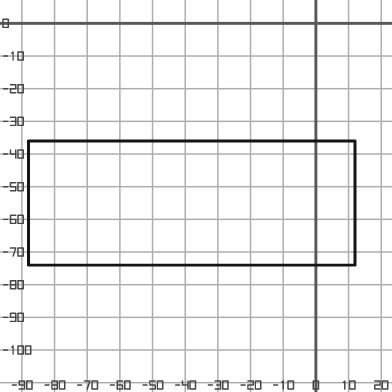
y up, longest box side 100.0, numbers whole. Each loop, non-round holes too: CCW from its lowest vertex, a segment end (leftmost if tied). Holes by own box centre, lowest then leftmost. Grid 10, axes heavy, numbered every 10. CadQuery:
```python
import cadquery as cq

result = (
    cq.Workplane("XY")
    .moveTo(-88.0, -74.0)
    .lineTo(12.0, -74.0)
    .lineTo(12.0, -36.0)
    .lineTo(-88.0, -36.0)
    .close()
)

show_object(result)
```